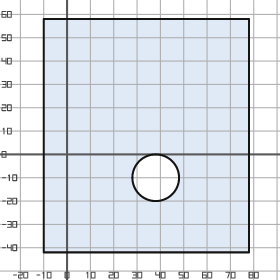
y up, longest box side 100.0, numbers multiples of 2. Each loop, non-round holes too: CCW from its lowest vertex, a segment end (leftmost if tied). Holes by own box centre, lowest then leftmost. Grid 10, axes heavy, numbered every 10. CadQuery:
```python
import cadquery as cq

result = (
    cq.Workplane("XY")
    .moveTo(-10.0, -42.0)
    .lineTo(78.0, -42.0)
    .lineTo(78.0, 58.0)
    .lineTo(-10.0, 58.0)
    .close()
    .moveTo(38.0, -10.0)
    .circle(10.0)
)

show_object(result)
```